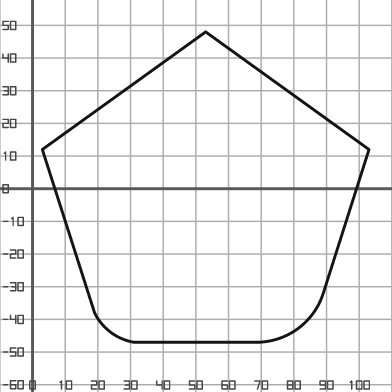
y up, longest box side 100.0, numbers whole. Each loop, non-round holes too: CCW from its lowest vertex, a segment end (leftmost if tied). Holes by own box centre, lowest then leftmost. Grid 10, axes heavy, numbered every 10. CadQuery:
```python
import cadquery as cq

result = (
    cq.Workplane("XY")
    .moveTo(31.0, -47.0)
    .lineTo(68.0, -47.0)
    .threePointArc((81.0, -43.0), (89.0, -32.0))
    .lineTo(103.0, 12.0)
    .lineTo(53.0, 48.0)
    .lineTo(3.0, 12.0)
    .lineTo(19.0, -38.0)
    .threePointArc((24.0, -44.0), (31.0, -47.0))
    .close()
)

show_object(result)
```